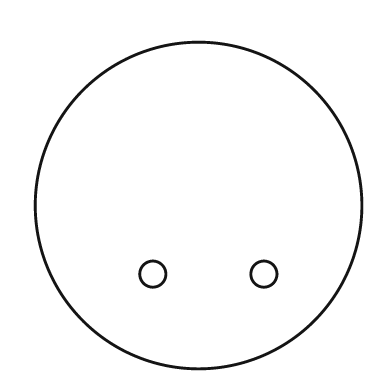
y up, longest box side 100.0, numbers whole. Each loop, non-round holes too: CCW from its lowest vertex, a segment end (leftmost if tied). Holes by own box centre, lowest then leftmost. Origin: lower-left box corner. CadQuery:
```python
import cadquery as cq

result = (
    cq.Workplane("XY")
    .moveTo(50.0, 50.0)
    .circle(50.0)
    .moveTo(36.0, 29.0)
    .circle(4.0)
    .moveTo(70.0, 29.0)
    .circle(4.0)
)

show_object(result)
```